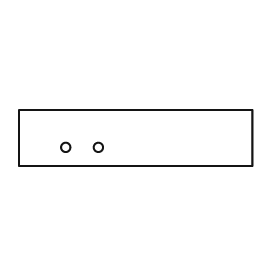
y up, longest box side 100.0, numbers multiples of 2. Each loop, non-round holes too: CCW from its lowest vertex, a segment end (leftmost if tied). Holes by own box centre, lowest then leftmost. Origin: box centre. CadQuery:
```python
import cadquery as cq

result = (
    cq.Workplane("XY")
    .moveTo(-50.0, -12.0)
    .lineTo(50.0, -12.0)
    .lineTo(50.0, 12.0)
    .lineTo(-50.0, 12.0)
    .close()
    .moveTo(-30.0, -4.0)
    .circle(2.0)
    .moveTo(-16.0, -4.0)
    .circle(2.0)
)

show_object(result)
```